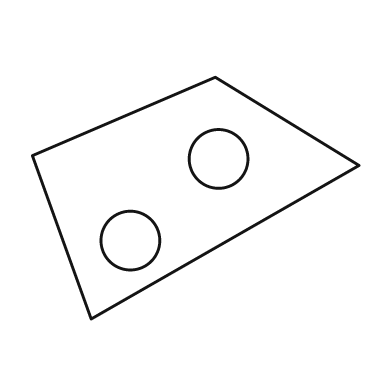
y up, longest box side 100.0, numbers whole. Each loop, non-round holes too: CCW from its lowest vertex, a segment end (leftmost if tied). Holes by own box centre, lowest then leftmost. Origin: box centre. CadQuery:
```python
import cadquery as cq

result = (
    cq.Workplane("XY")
    .moveTo(-32.0, -37.0)
    .lineTo(50.0, 10.0)
    .lineTo(6.0, 37.0)
    .lineTo(-50.0, 13.0)
    .close()
    .moveTo(-20.0, -13.0)
    .circle(9.0)
    .moveTo(7.0, 12.0)
    .circle(9.0)
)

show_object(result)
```